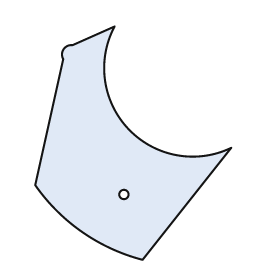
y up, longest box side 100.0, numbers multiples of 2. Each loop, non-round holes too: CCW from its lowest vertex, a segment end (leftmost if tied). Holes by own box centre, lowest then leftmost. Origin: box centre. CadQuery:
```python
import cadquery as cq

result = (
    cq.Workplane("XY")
    .moveTo(4.0, -50.0)
    .lineTo(42.0, -2.0)
    .threePointArc((-2.0, 6.0), (-8.0, 50.0))
    .lineTo(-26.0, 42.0)
    .threePointArc((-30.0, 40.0), (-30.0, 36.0))
    .lineTo(-42.0, -18.0)
    .threePointArc((-22.0, -38.0), (4.0, -50.0))
    .close()
    .moveTo(-4.0, -22.0)
    .circle(2.0)
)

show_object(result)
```